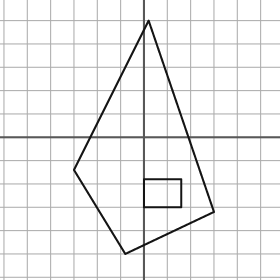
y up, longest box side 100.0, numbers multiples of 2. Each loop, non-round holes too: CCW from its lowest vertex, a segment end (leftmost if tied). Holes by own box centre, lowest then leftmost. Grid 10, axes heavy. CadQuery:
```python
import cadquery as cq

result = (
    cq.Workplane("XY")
    .moveTo(-8.0, -50.0)
    .lineTo(30.0, -32.0)
    .lineTo(2.0, 50.0)
    .lineTo(-30.0, -14.0)
    .close()
    .moveTo(0.0, -30.0)
    .lineTo(16.0, -30.0)
    .lineTo(16.0, -18.0)
    .lineTo(0.0, -18.0)
    .close()
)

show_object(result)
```